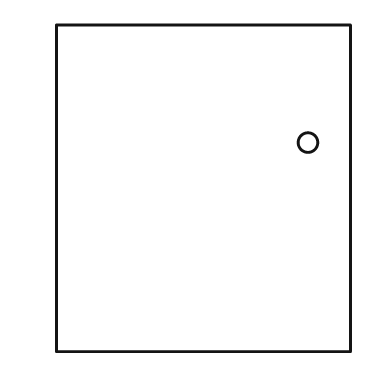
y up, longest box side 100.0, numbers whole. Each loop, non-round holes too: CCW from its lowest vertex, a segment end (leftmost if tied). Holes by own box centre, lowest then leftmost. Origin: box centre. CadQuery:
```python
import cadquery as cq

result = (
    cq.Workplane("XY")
    .moveTo(-45.0, -50.0)
    .lineTo(45.0, -50.0)
    .lineTo(45.0, 50.0)
    .lineTo(-45.0, 50.0)
    .close()
    .moveTo(32.0, 14.0)
    .circle(3.0)
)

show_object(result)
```